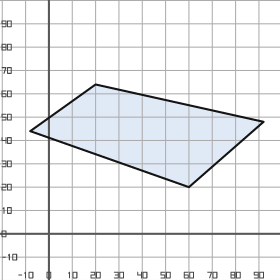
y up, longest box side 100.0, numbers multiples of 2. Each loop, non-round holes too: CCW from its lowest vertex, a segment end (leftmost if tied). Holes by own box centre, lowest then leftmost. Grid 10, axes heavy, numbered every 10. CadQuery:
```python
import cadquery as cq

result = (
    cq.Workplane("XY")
    .moveTo(60.0, 20.0)
    .lineTo(92.0, 48.0)
    .lineTo(20.0, 64.0)
    .lineTo(-8.0, 44.0)
    .close()
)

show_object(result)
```